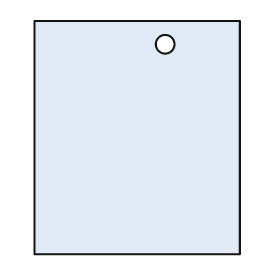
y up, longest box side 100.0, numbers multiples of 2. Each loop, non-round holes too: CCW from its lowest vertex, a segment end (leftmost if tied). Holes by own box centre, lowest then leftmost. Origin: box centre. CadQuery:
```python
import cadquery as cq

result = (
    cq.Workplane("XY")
    .moveTo(-44.0, -50.0)
    .lineTo(44.0, -50.0)
    .lineTo(44.0, 50.0)
    .lineTo(-44.0, 50.0)
    .close()
    .moveTo(12.0, 40.0)
    .circle(4.0)
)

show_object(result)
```